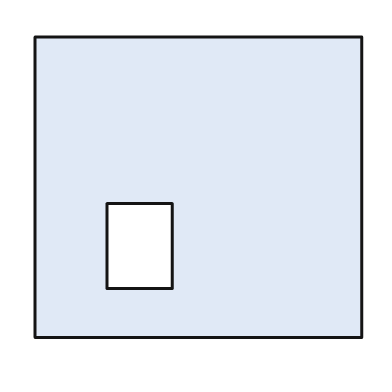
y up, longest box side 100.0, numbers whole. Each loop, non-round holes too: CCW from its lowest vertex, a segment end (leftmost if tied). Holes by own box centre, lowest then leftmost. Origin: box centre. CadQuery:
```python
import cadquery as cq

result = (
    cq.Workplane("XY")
    .moveTo(-50.0, -46.0)
    .lineTo(50.0, -46.0)
    .lineTo(50.0, 46.0)
    .lineTo(-50.0, 46.0)
    .close()
    .moveTo(-28.0, -31.0)
    .lineTo(-8.0, -31.0)
    .lineTo(-8.0, -5.0)
    .lineTo(-28.0, -5.0)
    .close()
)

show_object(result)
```